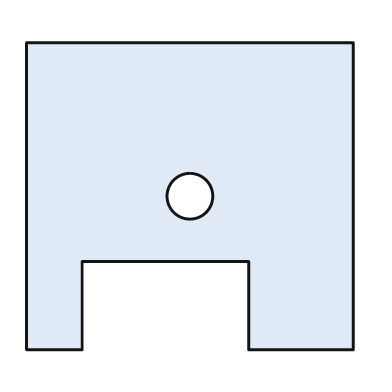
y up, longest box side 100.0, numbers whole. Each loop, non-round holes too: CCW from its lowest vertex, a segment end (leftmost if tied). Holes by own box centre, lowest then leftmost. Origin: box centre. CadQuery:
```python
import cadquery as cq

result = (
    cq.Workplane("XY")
    .moveTo(-50.0, -47.0)
    .lineTo(-33.0, -47.0)
    .lineTo(-33.0, -20.0)
    .lineTo(18.0, -20.0)
    .lineTo(18.0, -47.0)
    .lineTo(50.0, -47.0)
    .lineTo(50.0, 47.0)
    .lineTo(-50.0, 47.0)
    .close()
    .moveTo(0.0, 0.0)
    .circle(7.0)
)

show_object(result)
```